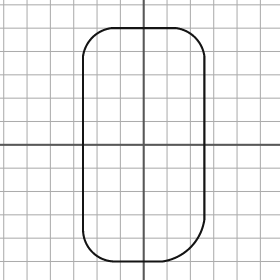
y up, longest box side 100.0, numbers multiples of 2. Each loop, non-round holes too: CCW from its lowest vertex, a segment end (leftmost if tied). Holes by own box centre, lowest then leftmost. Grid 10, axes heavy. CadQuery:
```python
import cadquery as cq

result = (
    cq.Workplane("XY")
    .moveTo(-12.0, -50.0)
    .lineTo(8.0, -50.0)
    .threePointArc((20.0, -44.0), (26.0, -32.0))
    .lineTo(26.0, 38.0)
    .threePointArc((22.0, 46.0), (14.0, 50.0))
    .lineTo(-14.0, 50.0)
    .threePointArc((-22.0, 46.0), (-26.0, 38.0))
    .lineTo(-26.0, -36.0)
    .threePointArc((-22.0, -46.0), (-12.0, -50.0))
    .close()
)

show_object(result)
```